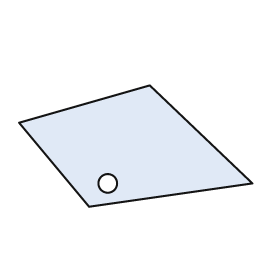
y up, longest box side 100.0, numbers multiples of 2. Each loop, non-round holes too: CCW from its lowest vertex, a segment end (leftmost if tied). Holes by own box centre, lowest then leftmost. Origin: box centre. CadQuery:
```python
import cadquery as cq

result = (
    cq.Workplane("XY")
    .moveTo(-20.0, -26.0)
    .lineTo(50.0, -16.0)
    .lineTo(6.0, 26.0)
    .lineTo(-50.0, 10.0)
    .close()
    .moveTo(-12.0, -16.0)
    .circle(4.0)
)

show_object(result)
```